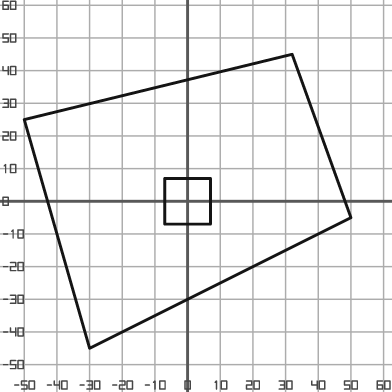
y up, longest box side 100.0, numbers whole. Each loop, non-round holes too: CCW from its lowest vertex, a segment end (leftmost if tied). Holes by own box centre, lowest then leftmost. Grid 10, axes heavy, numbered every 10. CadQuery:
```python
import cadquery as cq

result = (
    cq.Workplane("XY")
    .moveTo(-30.0, -45.0)
    .lineTo(50.0, -5.0)
    .lineTo(32.0, 45.0)
    .lineTo(-50.0, 25.0)
    .close()
    .moveTo(-7.0, -7.0)
    .lineTo(7.0, -7.0)
    .lineTo(7.0, 7.0)
    .lineTo(-7.0, 7.0)
    .close()
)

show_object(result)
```